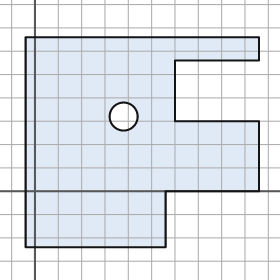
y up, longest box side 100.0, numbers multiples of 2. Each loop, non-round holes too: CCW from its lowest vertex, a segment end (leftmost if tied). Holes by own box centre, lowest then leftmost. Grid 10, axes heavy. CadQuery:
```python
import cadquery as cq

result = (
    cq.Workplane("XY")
    .moveTo(-4.0, -24.0)
    .lineTo(56.0, -24.0)
    .lineTo(56.0, 0.0)
    .lineTo(96.0, 0.0)
    .lineTo(96.0, 30.0)
    .lineTo(60.0, 30.0)
    .lineTo(60.0, 56.0)
    .lineTo(96.0, 56.0)
    .lineTo(96.0, 66.0)
    .lineTo(-4.0, 66.0)
    .close()
    .moveTo(38.0, 32.0)
    .circle(6.0)
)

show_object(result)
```